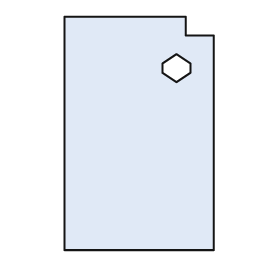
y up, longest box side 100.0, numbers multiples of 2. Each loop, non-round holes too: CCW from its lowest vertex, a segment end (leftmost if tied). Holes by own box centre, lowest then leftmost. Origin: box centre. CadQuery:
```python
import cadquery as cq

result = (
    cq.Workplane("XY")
    .moveTo(-32.0, -50.0)
    .lineTo(32.0, -50.0)
    .lineTo(32.0, 42.0)
    .lineTo(20.0, 42.0)
    .lineTo(20.0, 50.0)
    .lineTo(-32.0, 50.0)
    .close()
    .moveTo(16.0, 22.0)
    .lineTo(22.0, 26.0)
    .lineTo(22.0, 30.0)
    .lineTo(16.0, 34.0)
    .lineTo(10.0, 30.0)
    .lineTo(10.0, 26.0)
    .close()
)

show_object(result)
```